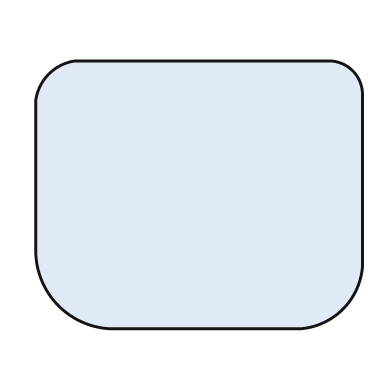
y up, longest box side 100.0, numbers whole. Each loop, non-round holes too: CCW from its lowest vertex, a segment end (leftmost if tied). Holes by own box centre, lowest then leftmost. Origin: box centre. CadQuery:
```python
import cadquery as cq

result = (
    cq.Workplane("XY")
    .moveTo(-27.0, -41.0)
    .lineTo(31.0, -41.0)
    .threePointArc((44.0, -35.0), (50.0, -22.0))
    .lineTo(50.0, 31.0)
    .threePointArc((47.0, 38.0), (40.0, 41.0))
    .lineTo(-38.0, 41.0)
    .threePointArc((-46.0, 37.0), (-50.0, 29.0))
    .lineTo(-50.0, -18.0)
    .threePointArc((-43.0, -34.0), (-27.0, -41.0))
    .close()
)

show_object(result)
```